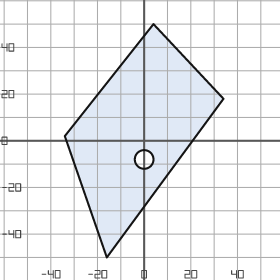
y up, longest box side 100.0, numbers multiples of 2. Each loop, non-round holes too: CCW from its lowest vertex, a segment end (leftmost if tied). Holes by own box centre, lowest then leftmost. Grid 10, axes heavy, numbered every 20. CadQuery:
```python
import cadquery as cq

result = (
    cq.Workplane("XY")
    .moveTo(-16.0, -50.0)
    .lineTo(34.0, 18.0)
    .lineTo(4.0, 50.0)
    .lineTo(-34.0, 2.0)
    .close()
    .moveTo(0.0, -8.0)
    .circle(4.0)
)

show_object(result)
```